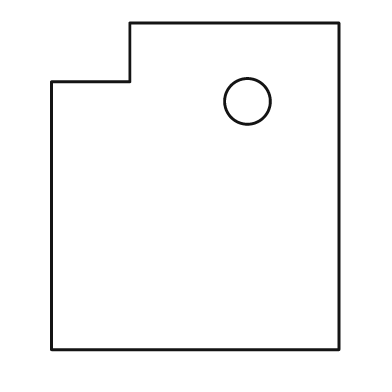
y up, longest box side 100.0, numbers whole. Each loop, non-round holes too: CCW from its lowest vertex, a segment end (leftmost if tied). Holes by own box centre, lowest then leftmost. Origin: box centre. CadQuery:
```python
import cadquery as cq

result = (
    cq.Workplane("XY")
    .moveTo(-44.0, -50.0)
    .lineTo(44.0, -50.0)
    .lineTo(44.0, 50.0)
    .lineTo(-20.0, 50.0)
    .lineTo(-20.0, 32.0)
    .lineTo(-44.0, 32.0)
    .close()
    .moveTo(16.0, 26.0)
    .circle(7.0)
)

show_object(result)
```